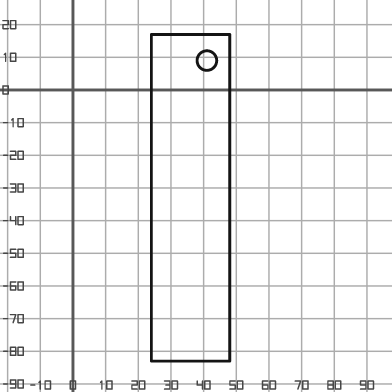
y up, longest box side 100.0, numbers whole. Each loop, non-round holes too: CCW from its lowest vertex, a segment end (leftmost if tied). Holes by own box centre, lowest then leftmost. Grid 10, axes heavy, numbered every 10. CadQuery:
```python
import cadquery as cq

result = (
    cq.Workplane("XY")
    .moveTo(24.0, -83.0)
    .lineTo(48.0, -83.0)
    .lineTo(48.0, 17.0)
    .lineTo(24.0, 17.0)
    .close()
    .moveTo(41.0, 9.0)
    .circle(3.0)
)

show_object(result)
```